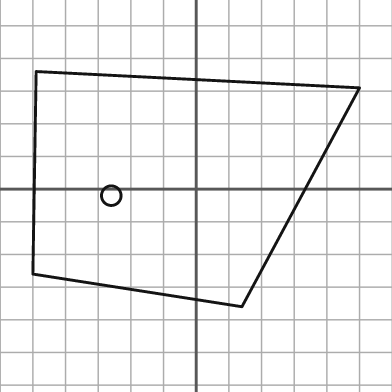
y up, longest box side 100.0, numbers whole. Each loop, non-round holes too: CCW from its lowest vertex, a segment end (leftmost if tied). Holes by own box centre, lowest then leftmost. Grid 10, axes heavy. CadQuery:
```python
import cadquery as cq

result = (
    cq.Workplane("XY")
    .moveTo(14.0, -36.0)
    .lineTo(50.0, 31.0)
    .lineTo(-49.0, 36.0)
    .lineTo(-50.0, -26.0)
    .close()
    .moveTo(-26.0, -2.0)
    .circle(3.0)
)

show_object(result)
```